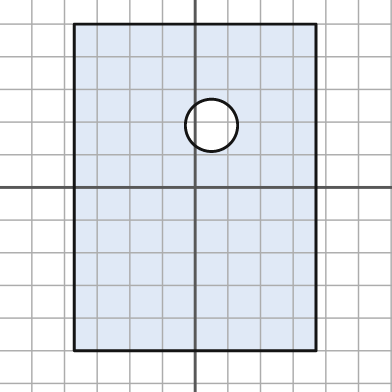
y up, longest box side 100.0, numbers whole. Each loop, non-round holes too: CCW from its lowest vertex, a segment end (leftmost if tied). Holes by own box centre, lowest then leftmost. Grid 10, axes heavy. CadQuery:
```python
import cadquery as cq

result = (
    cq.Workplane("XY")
    .moveTo(-37.0, -50.0)
    .lineTo(37.0, -50.0)
    .lineTo(37.0, 50.0)
    .lineTo(-37.0, 50.0)
    .close()
    .moveTo(5.0, 19.0)
    .circle(8.0)
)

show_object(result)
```